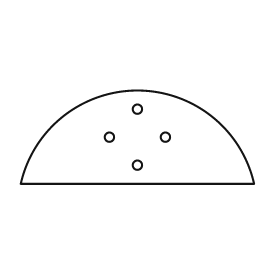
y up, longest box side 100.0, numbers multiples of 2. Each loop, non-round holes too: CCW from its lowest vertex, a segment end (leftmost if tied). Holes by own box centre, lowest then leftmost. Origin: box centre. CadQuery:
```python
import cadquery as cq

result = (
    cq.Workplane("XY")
    .moveTo(-50.0, -20.0)
    .lineTo(50.0, -20.0)
    .threePointArc((0.0, 20.0), (-50.0, -20.0))
    .close()
    .moveTo(0.0, -12.0)
    .circle(2.0)
    .moveTo(-12.0, 0.0)
    .circle(2.0)
    .moveTo(12.0, 0.0)
    .circle(2.0)
    .moveTo(0.0, 12.0)
    .circle(2.0)
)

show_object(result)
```